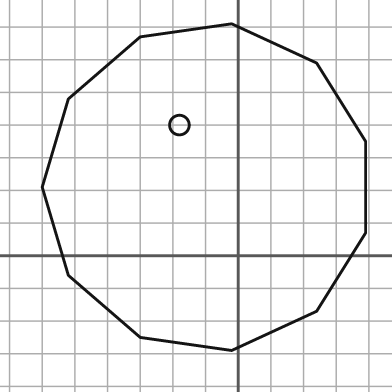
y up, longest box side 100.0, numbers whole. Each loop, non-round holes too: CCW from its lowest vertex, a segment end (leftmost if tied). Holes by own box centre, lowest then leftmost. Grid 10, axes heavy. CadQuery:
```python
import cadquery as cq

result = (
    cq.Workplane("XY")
    .moveTo(-2.0, -29.0)
    .lineTo(24.0, -17.0)
    .lineTo(39.0, 7.0)
    .lineTo(39.0, 35.0)
    .lineTo(24.0, 59.0)
    .lineTo(-2.0, 71.0)
    .lineTo(-30.0, 67.0)
    .lineTo(-52.0, 48.0)
    .lineTo(-60.0, 21.0)
    .lineTo(-52.0, -6.0)
    .lineTo(-30.0, -25.0)
    .close()
    .moveTo(-18.0, 40.0)
    .circle(3.0)
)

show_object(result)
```